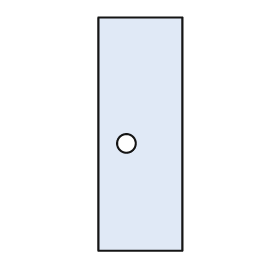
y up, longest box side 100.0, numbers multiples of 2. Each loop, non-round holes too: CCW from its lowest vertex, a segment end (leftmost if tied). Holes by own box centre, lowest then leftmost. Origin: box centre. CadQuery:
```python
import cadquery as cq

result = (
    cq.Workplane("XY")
    .moveTo(-18.0, -50.0)
    .lineTo(18.0, -50.0)
    .lineTo(18.0, 50.0)
    .lineTo(-18.0, 50.0)
    .close()
    .moveTo(-6.0, -4.0)
    .circle(4.0)
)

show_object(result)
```